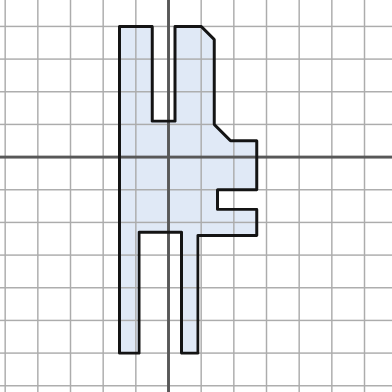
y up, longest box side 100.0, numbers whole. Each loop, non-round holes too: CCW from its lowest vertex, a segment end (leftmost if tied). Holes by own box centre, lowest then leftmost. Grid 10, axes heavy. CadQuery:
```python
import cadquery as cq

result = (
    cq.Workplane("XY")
    .moveTo(-15.0, -60.0)
    .lineTo(-9.0, -60.0)
    .lineTo(-9.0, -23.0)
    .lineTo(4.0, -23.0)
    .lineTo(4.0, -60.0)
    .lineTo(9.0, -60.0)
    .lineTo(9.0, -24.0)
    .lineTo(27.0, -24.0)
    .lineTo(27.0, -16.0)
    .lineTo(15.0, -16.0)
    .lineTo(15.0, -10.0)
    .lineTo(27.0, -10.0)
    .lineTo(27.0, 5.0)
    .lineTo(19.0, 5.0)
    .lineTo(14.0, 10.0)
    .lineTo(14.0, 36.0)
    .lineTo(10.0, 40.0)
    .lineTo(2.0, 40.0)
    .lineTo(2.0, 11.0)
    .lineTo(-5.0, 11.0)
    .lineTo(-5.0, 40.0)
    .lineTo(-15.0, 40.0)
    .close()
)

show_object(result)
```